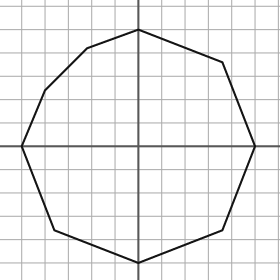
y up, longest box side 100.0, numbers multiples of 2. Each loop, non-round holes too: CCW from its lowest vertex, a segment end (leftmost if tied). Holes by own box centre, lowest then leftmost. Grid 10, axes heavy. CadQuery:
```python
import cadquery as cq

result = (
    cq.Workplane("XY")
    .moveTo(0.0, -50.0)
    .lineTo(36.0, -36.0)
    .lineTo(50.0, 0.0)
    .lineTo(36.0, 36.0)
    .lineTo(0.0, 50.0)
    .lineTo(-22.0, 42.0)
    .lineTo(-40.0, 24.0)
    .lineTo(-50.0, 0.0)
    .lineTo(-36.0, -36.0)
    .close()
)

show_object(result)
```